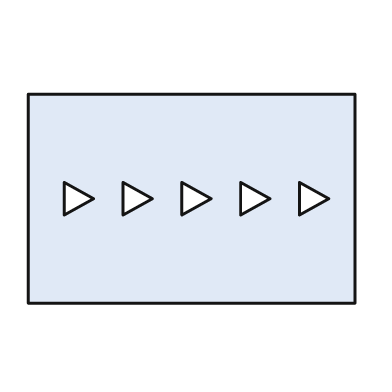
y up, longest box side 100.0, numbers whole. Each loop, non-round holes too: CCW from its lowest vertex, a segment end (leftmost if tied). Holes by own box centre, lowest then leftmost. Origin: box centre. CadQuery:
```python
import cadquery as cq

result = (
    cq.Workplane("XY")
    .moveTo(-50.0, -32.0)
    .lineTo(50.0, -32.0)
    .lineTo(50.0, 32.0)
    .lineTo(-50.0, 32.0)
    .close()
    .moveTo(-39.0, -5.0)
    .lineTo(-30.0, 0.0)
    .lineTo(-39.0, 5.0)
    .close()
    .moveTo(-21.0, -5.0)
    .lineTo(-12.0, 0.0)
    .lineTo(-21.0, 5.0)
    .close()
    .moveTo(-3.0, -5.0)
    .lineTo(6.0, 0.0)
    .lineTo(-3.0, 5.0)
    .close()
    .moveTo(15.0, -5.0)
    .lineTo(24.0, 0.0)
    .lineTo(15.0, 5.0)
    .close()
    .moveTo(33.0, -5.0)
    .lineTo(42.0, 0.0)
    .lineTo(33.0, 5.0)
    .close()
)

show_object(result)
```